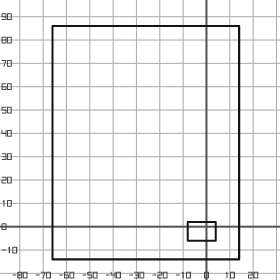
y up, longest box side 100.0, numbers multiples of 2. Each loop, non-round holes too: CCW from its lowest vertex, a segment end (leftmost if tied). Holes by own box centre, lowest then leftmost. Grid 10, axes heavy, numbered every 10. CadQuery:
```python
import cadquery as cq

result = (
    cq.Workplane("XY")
    .moveTo(-66.0, -14.0)
    .lineTo(14.0, -14.0)
    .lineTo(14.0, 86.0)
    .lineTo(-66.0, 86.0)
    .close()
    .moveTo(-8.0, -6.0)
    .lineTo(4.0, -6.0)
    .lineTo(4.0, 2.0)
    .lineTo(-8.0, 2.0)
    .close()
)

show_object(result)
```